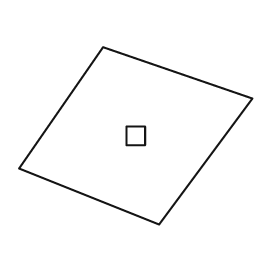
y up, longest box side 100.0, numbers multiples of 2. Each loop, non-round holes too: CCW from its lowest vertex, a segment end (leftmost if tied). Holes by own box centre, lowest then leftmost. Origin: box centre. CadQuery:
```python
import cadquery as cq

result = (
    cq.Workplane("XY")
    .moveTo(10.0, -38.0)
    .lineTo(50.0, 16.0)
    .lineTo(-14.0, 38.0)
    .lineTo(-50.0, -14.0)
    .close()
    .moveTo(-4.0, -4.0)
    .lineTo(4.0, -4.0)
    .lineTo(4.0, 4.0)
    .lineTo(-4.0, 4.0)
    .close()
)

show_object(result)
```